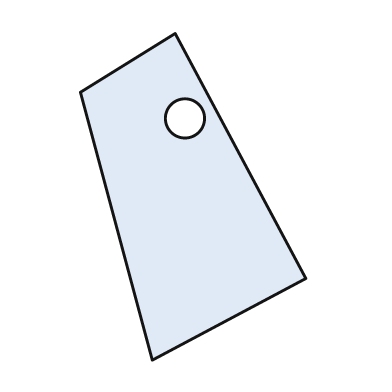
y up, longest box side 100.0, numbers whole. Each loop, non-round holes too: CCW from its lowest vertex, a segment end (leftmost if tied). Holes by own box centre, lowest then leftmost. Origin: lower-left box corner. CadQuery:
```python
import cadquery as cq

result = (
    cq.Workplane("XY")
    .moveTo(22.0, 0.0)
    .lineTo(69.0, 25.0)
    .lineTo(29.0, 100.0)
    .lineTo(0.0, 82.0)
    .close()
    .moveTo(32.0, 74.0)
    .circle(6.0)
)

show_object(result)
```